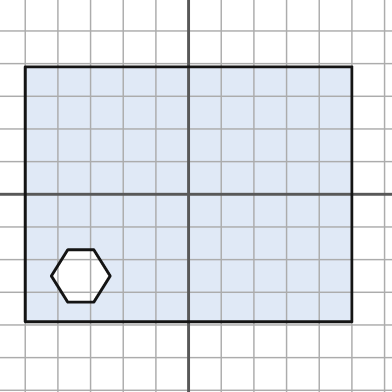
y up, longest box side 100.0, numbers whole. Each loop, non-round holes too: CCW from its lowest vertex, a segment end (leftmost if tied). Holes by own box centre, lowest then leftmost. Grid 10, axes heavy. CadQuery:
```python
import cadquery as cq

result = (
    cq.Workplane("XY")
    .moveTo(-50.0, -39.0)
    .lineTo(50.0, -39.0)
    .lineTo(50.0, 39.0)
    .lineTo(-50.0, 39.0)
    .close()
    .moveTo(-37.0, -33.0)
    .lineTo(-29.0, -33.0)
    .lineTo(-24.0, -25.0)
    .lineTo(-29.0, -17.0)
    .lineTo(-37.0, -17.0)
    .lineTo(-42.0, -25.0)
    .close()
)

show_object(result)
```